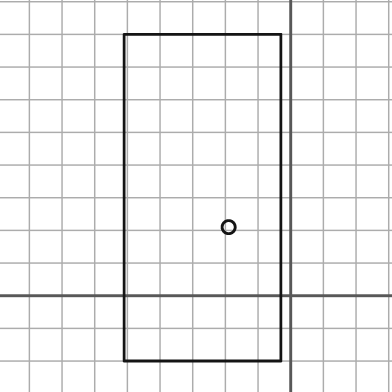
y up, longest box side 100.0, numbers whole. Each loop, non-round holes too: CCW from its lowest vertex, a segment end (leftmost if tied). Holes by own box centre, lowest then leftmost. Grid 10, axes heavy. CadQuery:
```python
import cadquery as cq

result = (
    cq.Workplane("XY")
    .moveTo(-51.0, -20.0)
    .lineTo(-3.0, -20.0)
    .lineTo(-3.0, 80.0)
    .lineTo(-51.0, 80.0)
    .close()
    .moveTo(-19.0, 21.0)
    .circle(2.0)
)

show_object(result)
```